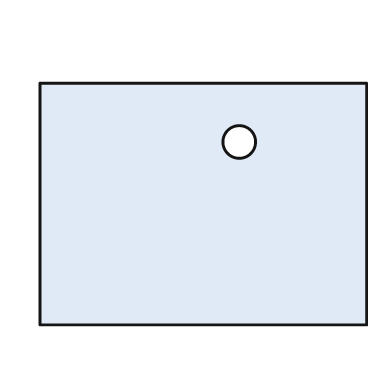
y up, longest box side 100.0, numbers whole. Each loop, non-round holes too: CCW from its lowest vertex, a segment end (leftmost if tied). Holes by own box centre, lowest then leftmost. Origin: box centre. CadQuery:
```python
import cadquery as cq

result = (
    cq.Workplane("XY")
    .moveTo(-50.0, -37.0)
    .lineTo(50.0, -37.0)
    .lineTo(50.0, 37.0)
    .lineTo(-50.0, 37.0)
    .close()
    .moveTo(11.0, 19.0)
    .circle(5.0)
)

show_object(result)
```